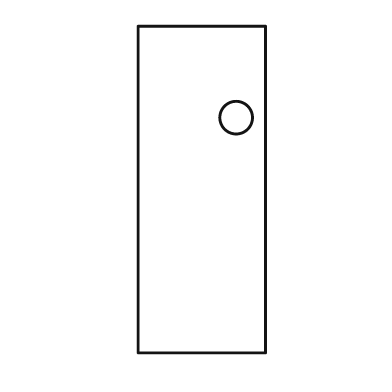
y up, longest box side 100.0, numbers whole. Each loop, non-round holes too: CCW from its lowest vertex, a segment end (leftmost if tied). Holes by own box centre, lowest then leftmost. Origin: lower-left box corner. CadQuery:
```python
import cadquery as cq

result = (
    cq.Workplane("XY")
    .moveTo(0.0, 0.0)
    .lineTo(39.0, 0.0)
    .lineTo(39.0, 100.0)
    .lineTo(0.0, 100.0)
    .close()
    .moveTo(30.0, 72.0)
    .circle(5.0)
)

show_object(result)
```